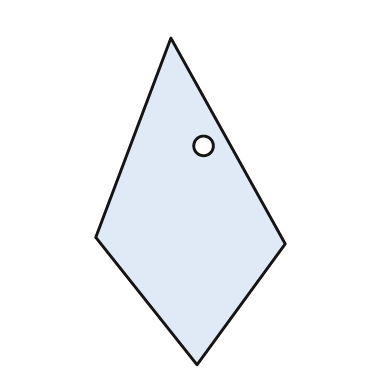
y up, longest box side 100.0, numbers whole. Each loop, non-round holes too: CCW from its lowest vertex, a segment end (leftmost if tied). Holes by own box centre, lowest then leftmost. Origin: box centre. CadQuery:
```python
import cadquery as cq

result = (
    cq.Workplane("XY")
    .moveTo(2.0, -50.0)
    .lineTo(29.0, -13.0)
    .lineTo(-6.0, 50.0)
    .lineTo(-29.0, -11.0)
    .close()
    .moveTo(4.0, 17.0)
    .circle(3.0)
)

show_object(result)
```